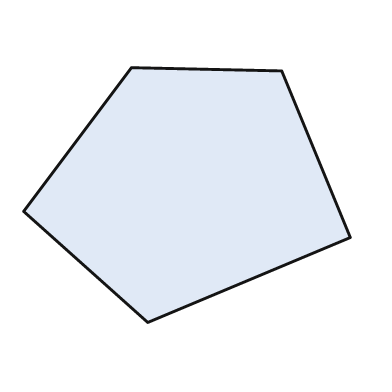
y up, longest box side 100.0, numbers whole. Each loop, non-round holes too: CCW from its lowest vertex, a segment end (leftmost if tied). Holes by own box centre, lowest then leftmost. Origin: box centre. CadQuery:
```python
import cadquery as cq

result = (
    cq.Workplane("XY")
    .moveTo(-12.0, -39.0)
    .lineTo(50.0, -13.0)
    .lineTo(29.0, 38.0)
    .lineTo(-17.0, 39.0)
    .lineTo(-50.0, -5.0)
    .close()
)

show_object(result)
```